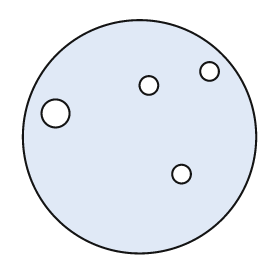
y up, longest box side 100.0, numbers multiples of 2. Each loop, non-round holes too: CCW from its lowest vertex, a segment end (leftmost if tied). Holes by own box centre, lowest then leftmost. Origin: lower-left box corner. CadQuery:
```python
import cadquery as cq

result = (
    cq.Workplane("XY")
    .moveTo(50.0, 50.0)
    .circle(50.0)
    .moveTo(68.0, 34.0)
    .circle(4.0)
    .moveTo(14.0, 60.0)
    .circle(6.0)
    .moveTo(54.0, 72.0)
    .circle(4.0)
    .moveTo(80.0, 78.0)
    .circle(4.0)
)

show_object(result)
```